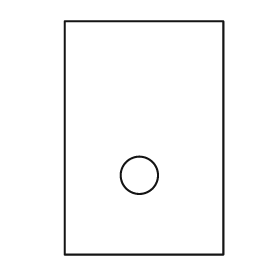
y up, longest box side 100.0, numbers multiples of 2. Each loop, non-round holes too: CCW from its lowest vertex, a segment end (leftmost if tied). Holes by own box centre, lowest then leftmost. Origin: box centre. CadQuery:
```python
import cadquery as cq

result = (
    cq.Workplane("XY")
    .moveTo(-34.0, -50.0)
    .lineTo(34.0, -50.0)
    .lineTo(34.0, 50.0)
    .lineTo(-34.0, 50.0)
    .close()
    .moveTo(-2.0, -16.0)
    .circle(8.0)
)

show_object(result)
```